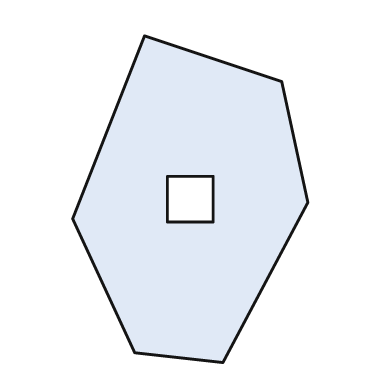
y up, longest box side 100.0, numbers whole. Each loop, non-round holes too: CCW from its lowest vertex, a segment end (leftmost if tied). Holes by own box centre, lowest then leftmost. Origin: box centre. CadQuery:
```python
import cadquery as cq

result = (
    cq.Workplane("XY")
    .moveTo(10.0, -50.0)
    .lineTo(36.0, -1.0)
    .lineTo(28.0, 36.0)
    .lineTo(-14.0, 50.0)
    .lineTo(-36.0, -6.0)
    .lineTo(-17.0, -47.0)
    .close()
    .moveTo(-7.0, -7.0)
    .lineTo(7.0, -7.0)
    .lineTo(7.0, 7.0)
    .lineTo(-7.0, 7.0)
    .close()
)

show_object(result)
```